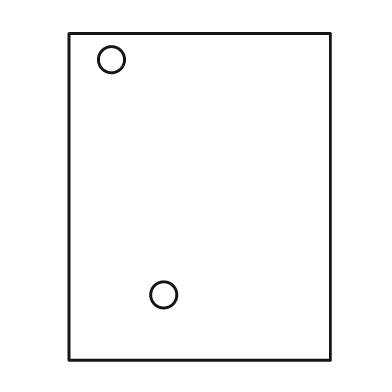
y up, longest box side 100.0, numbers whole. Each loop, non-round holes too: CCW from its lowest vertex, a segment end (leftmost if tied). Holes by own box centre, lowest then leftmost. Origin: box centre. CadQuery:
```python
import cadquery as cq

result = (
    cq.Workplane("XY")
    .moveTo(-40.0, -50.0)
    .lineTo(40.0, -50.0)
    .lineTo(40.0, 50.0)
    .lineTo(-40.0, 50.0)
    .close()
    .moveTo(-11.0, -30.0)
    .circle(4.0)
    .moveTo(-27.0, 42.0)
    .circle(4.0)
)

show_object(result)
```